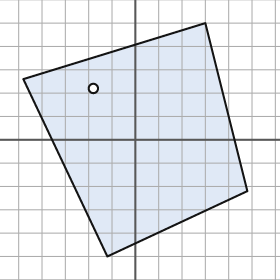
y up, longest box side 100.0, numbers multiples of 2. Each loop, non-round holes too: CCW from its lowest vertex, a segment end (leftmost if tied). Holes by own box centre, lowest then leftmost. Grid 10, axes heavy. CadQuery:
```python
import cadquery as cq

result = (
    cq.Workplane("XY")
    .moveTo(-12.0, -50.0)
    .lineTo(48.0, -22.0)
    .lineTo(30.0, 50.0)
    .lineTo(-48.0, 26.0)
    .close()
    .moveTo(-18.0, 22.0)
    .circle(2.0)
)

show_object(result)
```